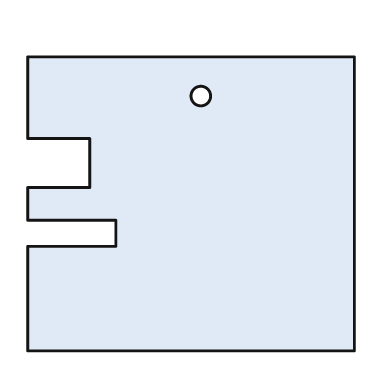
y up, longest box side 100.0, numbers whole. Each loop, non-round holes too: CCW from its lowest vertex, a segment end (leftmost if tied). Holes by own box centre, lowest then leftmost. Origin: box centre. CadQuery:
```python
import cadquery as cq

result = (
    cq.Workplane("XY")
    .moveTo(-50.0, -45.0)
    .lineTo(50.0, -45.0)
    .lineTo(50.0, 45.0)
    .lineTo(-50.0, 45.0)
    .lineTo(-50.0, 20.0)
    .lineTo(-31.0, 20.0)
    .lineTo(-31.0, 5.0)
    .lineTo(-50.0, 5.0)
    .lineTo(-50.0, -5.0)
    .lineTo(-23.0, -5.0)
    .lineTo(-23.0, -13.0)
    .lineTo(-50.0, -13.0)
    .close()
    .moveTo(3.0, 33.0)
    .circle(3.0)
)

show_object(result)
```